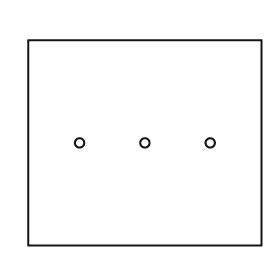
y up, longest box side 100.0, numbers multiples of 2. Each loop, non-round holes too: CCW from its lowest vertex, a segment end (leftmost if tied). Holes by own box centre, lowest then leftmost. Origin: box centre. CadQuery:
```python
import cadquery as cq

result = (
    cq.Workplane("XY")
    .moveTo(-50.0, -44.0)
    .lineTo(50.0, -44.0)
    .lineTo(50.0, 44.0)
    .lineTo(-50.0, 44.0)
    .close()
    .moveTo(-28.0, 0.0)
    .circle(2.0)
    .moveTo(0.0, 0.0)
    .circle(2.0)
    .moveTo(28.0, 0.0)
    .circle(2.0)
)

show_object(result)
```